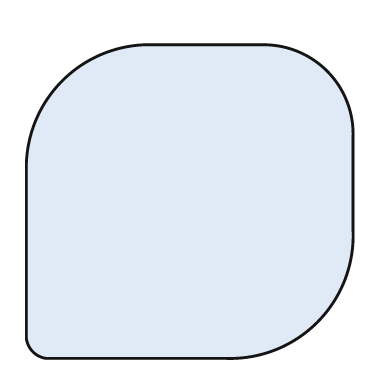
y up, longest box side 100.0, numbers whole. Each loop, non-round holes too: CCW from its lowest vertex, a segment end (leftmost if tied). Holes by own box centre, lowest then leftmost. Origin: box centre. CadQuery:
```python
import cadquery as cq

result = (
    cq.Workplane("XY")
    .moveTo(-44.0, -48.0)
    .lineTo(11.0, -48.0)
    .threePointArc((39.0, -37.0), (50.0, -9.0))
    .lineTo(50.0, 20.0)
    .threePointArc((42.0, 40.0), (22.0, 48.0))
    .lineTo(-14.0, 48.0)
    .threePointArc((-39.0, 37.0), (-50.0, 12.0))
    .lineTo(-50.0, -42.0)
    .threePointArc((-48.0, -46.0), (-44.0, -48.0))
    .close()
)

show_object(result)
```